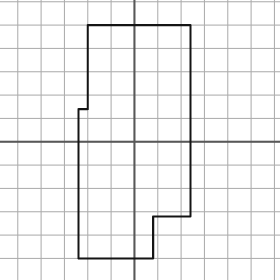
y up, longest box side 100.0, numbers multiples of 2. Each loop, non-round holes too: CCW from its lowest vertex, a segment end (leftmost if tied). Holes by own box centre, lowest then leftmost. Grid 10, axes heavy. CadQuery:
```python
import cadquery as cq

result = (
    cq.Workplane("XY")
    .moveTo(-24.0, -50.0)
    .lineTo(8.0, -50.0)
    .lineTo(8.0, -32.0)
    .lineTo(24.0, -32.0)
    .lineTo(24.0, 50.0)
    .lineTo(-20.0, 50.0)
    .lineTo(-20.0, 14.0)
    .lineTo(-24.0, 14.0)
    .close()
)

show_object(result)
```